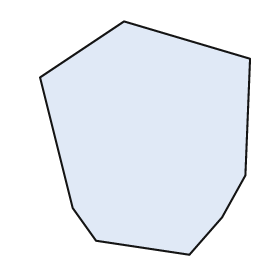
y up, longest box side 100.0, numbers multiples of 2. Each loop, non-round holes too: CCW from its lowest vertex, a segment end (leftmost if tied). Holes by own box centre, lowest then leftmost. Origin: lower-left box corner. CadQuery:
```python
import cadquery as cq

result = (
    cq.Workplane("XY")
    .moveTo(64.0, 0.0)
    .lineTo(78.0, 16.0)
    .lineTo(88.0, 34.0)
    .lineTo(90.0, 84.0)
    .lineTo(36.0, 100.0)
    .lineTo(0.0, 76.0)
    .lineTo(14.0, 20.0)
    .lineTo(24.0, 6.0)
    .close()
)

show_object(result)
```